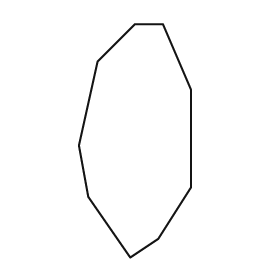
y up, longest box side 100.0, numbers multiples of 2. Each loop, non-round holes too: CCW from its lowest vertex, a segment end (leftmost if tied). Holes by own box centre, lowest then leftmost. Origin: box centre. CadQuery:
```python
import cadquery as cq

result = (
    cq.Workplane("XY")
    .moveTo(-2.0, -50.0)
    .lineTo(10.0, -42.0)
    .lineTo(24.0, -20.0)
    .lineTo(24.0, 22.0)
    .lineTo(12.0, 50.0)
    .lineTo(0.0, 50.0)
    .lineTo(-16.0, 34.0)
    .lineTo(-24.0, -2.0)
    .lineTo(-20.0, -24.0)
    .close()
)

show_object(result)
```